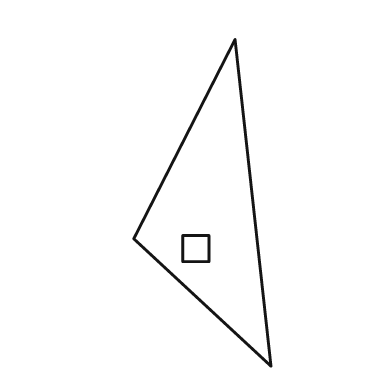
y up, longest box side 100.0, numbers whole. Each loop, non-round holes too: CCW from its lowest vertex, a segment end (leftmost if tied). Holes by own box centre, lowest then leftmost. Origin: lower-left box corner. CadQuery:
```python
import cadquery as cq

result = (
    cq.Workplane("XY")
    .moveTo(42.0, 0.0)
    .lineTo(31.0, 100.0)
    .lineTo(0.0, 39.0)
    .close()
    .moveTo(15.0, 32.0)
    .lineTo(23.0, 32.0)
    .lineTo(23.0, 40.0)
    .lineTo(15.0, 40.0)
    .close()
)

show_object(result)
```